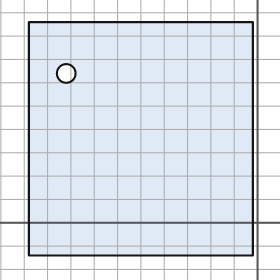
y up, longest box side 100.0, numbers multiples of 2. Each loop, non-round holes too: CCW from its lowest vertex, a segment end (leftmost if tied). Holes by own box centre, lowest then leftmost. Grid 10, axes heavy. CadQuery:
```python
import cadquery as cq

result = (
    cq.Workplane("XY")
    .moveTo(-98.0, -14.0)
    .lineTo(-2.0, -14.0)
    .lineTo(-2.0, 86.0)
    .lineTo(-98.0, 86.0)
    .close()
    .moveTo(-82.0, 64.0)
    .circle(4.0)
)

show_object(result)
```